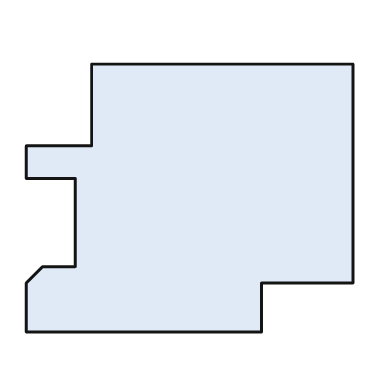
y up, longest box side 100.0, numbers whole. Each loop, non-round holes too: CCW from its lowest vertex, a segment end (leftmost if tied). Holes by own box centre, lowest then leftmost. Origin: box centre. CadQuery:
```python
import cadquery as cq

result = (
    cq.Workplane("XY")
    .moveTo(-50.0, -41.0)
    .lineTo(22.0, -41.0)
    .lineTo(22.0, -26.0)
    .lineTo(50.0, -26.0)
    .lineTo(50.0, 41.0)
    .lineTo(-30.0, 41.0)
    .lineTo(-30.0, 16.0)
    .lineTo(-50.0, 16.0)
    .lineTo(-50.0, 6.0)
    .lineTo(-35.0, 6.0)
    .lineTo(-35.0, -21.0)
    .lineTo(-45.0, -21.0)
    .lineTo(-50.0, -26.0)
    .close()
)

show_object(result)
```